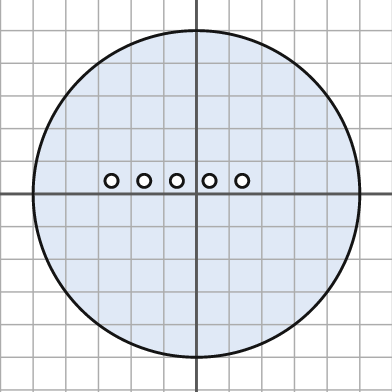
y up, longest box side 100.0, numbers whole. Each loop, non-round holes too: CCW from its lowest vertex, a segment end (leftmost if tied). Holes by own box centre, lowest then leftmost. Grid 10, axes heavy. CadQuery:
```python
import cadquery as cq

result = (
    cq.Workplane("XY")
    .moveTo(0.0, 0.0)
    .circle(50.0)
    .moveTo(-26.0, 4.0)
    .circle(2.0)
    .moveTo(-16.0, 4.0)
    .circle(2.0)
    .moveTo(-6.0, 4.0)
    .circle(2.0)
    .moveTo(4.0, 4.0)
    .circle(2.0)
    .moveTo(14.0, 4.0)
    .circle(2.0)
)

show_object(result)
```